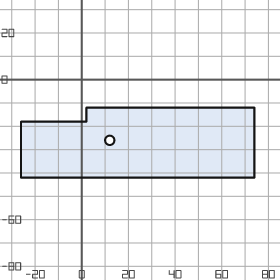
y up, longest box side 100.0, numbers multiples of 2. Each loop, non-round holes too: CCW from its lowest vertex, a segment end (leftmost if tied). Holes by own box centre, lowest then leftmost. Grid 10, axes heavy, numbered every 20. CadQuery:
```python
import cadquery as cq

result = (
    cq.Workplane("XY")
    .moveTo(-26.0, -42.0)
    .lineTo(74.0, -42.0)
    .lineTo(74.0, -12.0)
    .lineTo(2.0, -12.0)
    .lineTo(2.0, -18.0)
    .lineTo(-26.0, -18.0)
    .close()
    .moveTo(12.0, -26.0)
    .circle(2.0)
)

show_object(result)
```